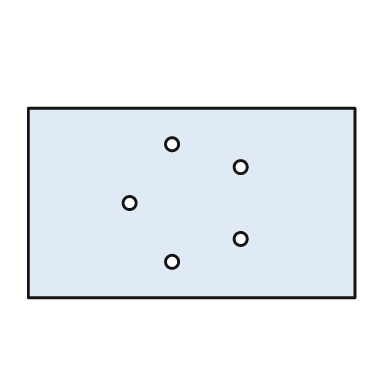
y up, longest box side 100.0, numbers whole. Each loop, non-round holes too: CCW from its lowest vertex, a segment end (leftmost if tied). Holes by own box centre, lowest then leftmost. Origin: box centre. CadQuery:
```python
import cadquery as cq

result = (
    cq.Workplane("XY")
    .moveTo(-50.0, -29.0)
    .lineTo(50.0, -29.0)
    .lineTo(50.0, 29.0)
    .lineTo(-50.0, 29.0)
    .close()
    .moveTo(-6.0, -18.0)
    .circle(2.0)
    .moveTo(15.0, -11.0)
    .circle(2.0)
    .moveTo(-19.0, 0.0)
    .circle(2.0)
    .moveTo(15.0, 11.0)
    .circle(2.0)
    .moveTo(-6.0, 18.0)
    .circle(2.0)
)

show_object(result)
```